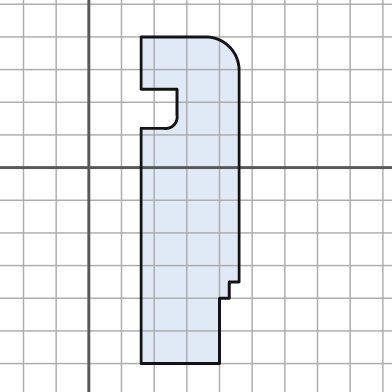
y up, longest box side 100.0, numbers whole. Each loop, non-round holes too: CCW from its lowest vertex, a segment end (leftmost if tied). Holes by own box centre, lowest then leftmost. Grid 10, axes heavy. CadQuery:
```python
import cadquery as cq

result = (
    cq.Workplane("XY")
    .moveTo(16.0, -60.0)
    .lineTo(40.0, -60.0)
    .lineTo(40.0, -40.0)
    .lineTo(43.0, -40.0)
    .lineTo(43.0, -35.0)
    .lineTo(46.0, -35.0)
    .lineTo(46.0, 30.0)
    .threePointArc((43.0, 37.0), (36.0, 40.0))
    .lineTo(16.0, 40.0)
    .lineTo(16.0, 24.0)
    .lineTo(27.0, 24.0)
    .lineTo(27.0, 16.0)
    .threePointArc((26.0, 13.0), (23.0, 12.0))
    .lineTo(16.0, 12.0)
    .close()
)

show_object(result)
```